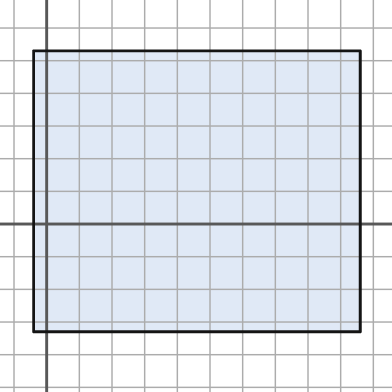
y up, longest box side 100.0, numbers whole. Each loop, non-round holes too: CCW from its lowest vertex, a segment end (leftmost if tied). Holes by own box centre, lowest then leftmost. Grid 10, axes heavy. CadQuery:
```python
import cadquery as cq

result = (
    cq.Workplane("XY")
    .moveTo(-4.0, -33.0)
    .lineTo(96.0, -33.0)
    .lineTo(96.0, 53.0)
    .lineTo(-4.0, 53.0)
    .close()
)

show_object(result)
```